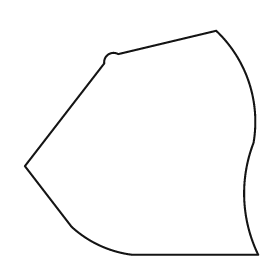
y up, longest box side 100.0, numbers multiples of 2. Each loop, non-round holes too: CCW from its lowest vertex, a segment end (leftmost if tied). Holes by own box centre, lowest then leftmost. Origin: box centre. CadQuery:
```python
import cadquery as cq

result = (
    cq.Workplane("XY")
    .moveTo(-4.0, -48.0)
    .lineTo(50.0, -48.0)
    .threePointArc((44.0, -24.0), (48.0, 0.0))
    .threePointArc((46.0, 26.0), (32.0, 48.0))
    .lineTo(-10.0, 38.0)
    .threePointArc((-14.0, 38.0), (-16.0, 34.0))
    .lineTo(-50.0, -10.0)
    .lineTo(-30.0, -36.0)
    .threePointArc((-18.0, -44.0), (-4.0, -48.0))
    .close()
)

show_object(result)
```